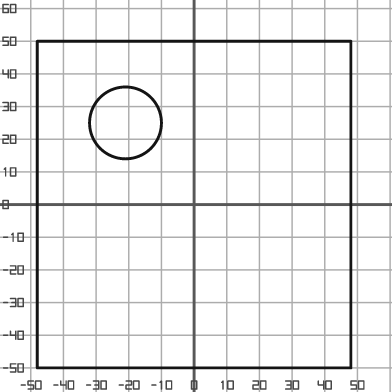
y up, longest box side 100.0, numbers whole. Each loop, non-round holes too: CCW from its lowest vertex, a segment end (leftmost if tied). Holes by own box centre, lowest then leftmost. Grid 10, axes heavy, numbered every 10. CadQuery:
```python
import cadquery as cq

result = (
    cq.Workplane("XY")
    .moveTo(-48.0, -50.0)
    .lineTo(48.0, -50.0)
    .lineTo(48.0, 50.0)
    .lineTo(-48.0, 50.0)
    .close()
    .moveTo(-21.0, 25.0)
    .circle(11.0)
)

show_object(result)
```